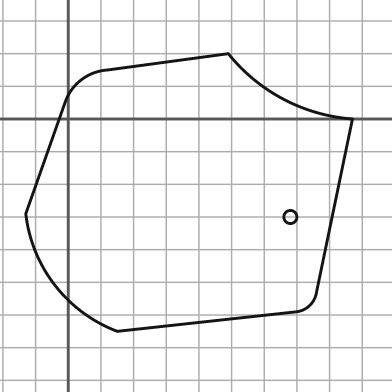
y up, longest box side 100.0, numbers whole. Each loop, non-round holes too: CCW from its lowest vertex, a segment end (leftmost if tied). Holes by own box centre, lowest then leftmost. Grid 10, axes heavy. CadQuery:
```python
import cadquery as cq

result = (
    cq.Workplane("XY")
    .moveTo(15.0, -65.0)
    .lineTo(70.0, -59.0)
    .threePointArc((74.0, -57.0), (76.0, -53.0))
    .lineTo(87.0, 0.0)
    .threePointArc((66.0, 6.0), (49.0, 20.0))
    .lineTo(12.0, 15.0)
    .threePointArc((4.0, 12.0), (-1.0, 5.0))
    .lineTo(-13.0, -29.0)
    .threePointArc((-4.0, -51.0), (15.0, -65.0))
    .close()
    .moveTo(68.0, -30.0)
    .circle(2.0)
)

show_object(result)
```